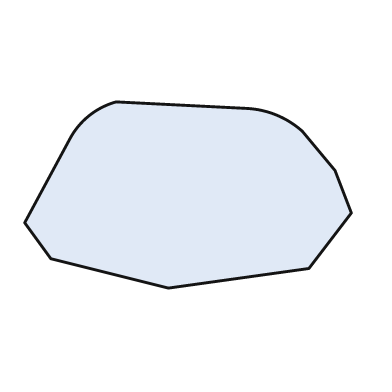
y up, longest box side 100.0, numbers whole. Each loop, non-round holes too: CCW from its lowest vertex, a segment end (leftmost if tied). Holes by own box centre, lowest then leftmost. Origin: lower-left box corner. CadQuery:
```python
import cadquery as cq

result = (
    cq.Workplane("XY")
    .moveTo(44.0, 0.0)
    .lineTo(87.0, 6.0)
    .lineTo(100.0, 23.0)
    .lineTo(95.0, 36.0)
    .lineTo(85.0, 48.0)
    .threePointArc((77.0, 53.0), (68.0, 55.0))
    .lineTo(28.0, 57.0)
    .threePointArc((20.0, 53.0), (14.0, 46.0))
    .lineTo(0.0, 20.0)
    .lineTo(8.0, 9.0)
    .close()
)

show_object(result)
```